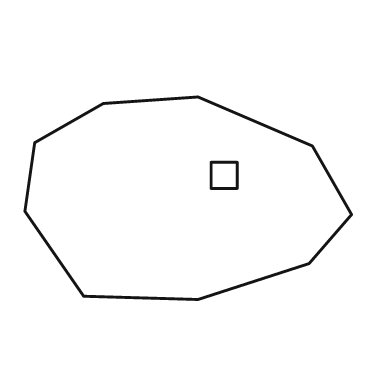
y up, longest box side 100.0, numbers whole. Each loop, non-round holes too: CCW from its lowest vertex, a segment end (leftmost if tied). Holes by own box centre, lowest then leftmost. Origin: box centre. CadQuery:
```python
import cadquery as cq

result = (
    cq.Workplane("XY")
    .moveTo(3.0, -31.0)
    .lineTo(37.0, -20.0)
    .lineTo(50.0, -5.0)
    .lineTo(38.0, 16.0)
    .lineTo(3.0, 31.0)
    .lineTo(-26.0, 29.0)
    .lineTo(-47.0, 17.0)
    .lineTo(-50.0, -4.0)
    .lineTo(-32.0, -30.0)
    .close()
    .moveTo(7.0, 3.0)
    .lineTo(15.0, 3.0)
    .lineTo(15.0, 11.0)
    .lineTo(7.0, 11.0)
    .close()
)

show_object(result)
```